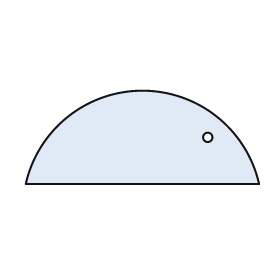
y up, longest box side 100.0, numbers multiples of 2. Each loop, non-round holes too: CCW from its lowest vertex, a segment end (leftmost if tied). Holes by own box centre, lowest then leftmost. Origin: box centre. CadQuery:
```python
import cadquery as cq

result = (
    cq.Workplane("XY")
    .moveTo(-50.0, -20.0)
    .lineTo(50.0, -20.0)
    .threePointArc((0.0, 20.0), (-50.0, -20.0))
    .close()
    .moveTo(28.0, 0.0)
    .circle(2.0)
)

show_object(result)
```